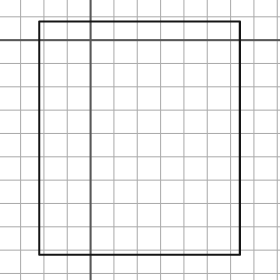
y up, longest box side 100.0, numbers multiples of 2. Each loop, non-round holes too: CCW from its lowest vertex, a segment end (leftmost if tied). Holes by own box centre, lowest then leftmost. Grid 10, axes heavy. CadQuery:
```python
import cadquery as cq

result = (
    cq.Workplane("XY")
    .moveTo(-22.0, -92.0)
    .lineTo(64.0, -92.0)
    .lineTo(64.0, 8.0)
    .lineTo(-22.0, 8.0)
    .close()
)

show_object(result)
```